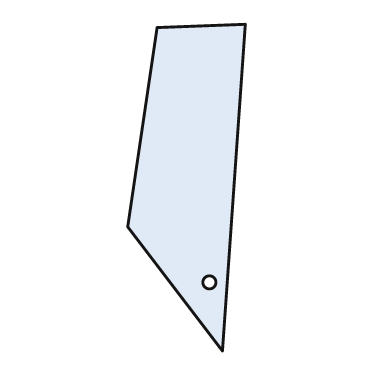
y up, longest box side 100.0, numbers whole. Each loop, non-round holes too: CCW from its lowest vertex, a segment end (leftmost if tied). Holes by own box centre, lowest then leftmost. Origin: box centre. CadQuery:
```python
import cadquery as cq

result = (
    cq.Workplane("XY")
    .moveTo(11.0, -50.0)
    .lineTo(18.0, 50.0)
    .lineTo(-9.0, 49.0)
    .lineTo(-18.0, -12.0)
    .close()
    .moveTo(7.0, -29.0)
    .circle(2.0)
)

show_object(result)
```